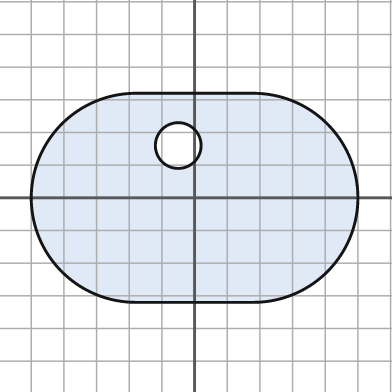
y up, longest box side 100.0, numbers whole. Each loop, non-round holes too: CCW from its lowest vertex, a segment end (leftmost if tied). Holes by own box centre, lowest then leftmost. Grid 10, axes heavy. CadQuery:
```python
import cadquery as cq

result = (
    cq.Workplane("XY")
    .moveTo(-18.0, -32.0)
    .lineTo(18.0, -32.0)
    .threePointArc((50.0, 0.0), (18.0, 32.0))
    .lineTo(-18.0, 32.0)
    .threePointArc((-50.0, 0.0), (-18.0, -32.0))
    .close()
    .moveTo(-5.0, 16.0)
    .circle(7.0)
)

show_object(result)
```